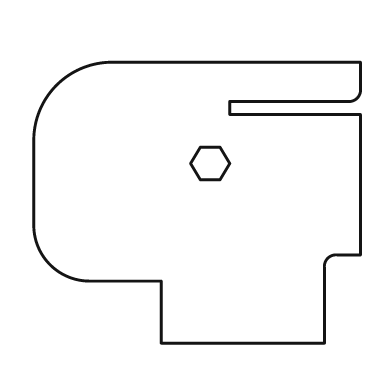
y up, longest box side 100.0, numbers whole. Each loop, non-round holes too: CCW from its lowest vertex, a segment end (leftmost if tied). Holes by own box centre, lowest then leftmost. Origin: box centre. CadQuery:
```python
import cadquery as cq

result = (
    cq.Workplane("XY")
    .moveTo(-11.0, -43.0)
    .lineTo(39.0, -43.0)
    .lineTo(39.0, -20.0)
    .threePointArc((40.0, -17.0), (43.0, -16.0))
    .lineTo(50.0, -16.0)
    .lineTo(50.0, 27.0)
    .lineTo(10.0, 27.0)
    .lineTo(10.0, 31.0)
    .lineTo(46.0, 31.0)
    .threePointArc((49.0, 32.0), (50.0, 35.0))
    .lineTo(50.0, 43.0)
    .lineTo(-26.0, 43.0)
    .threePointArc((-43.0, 36.0), (-50.0, 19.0))
    .lineTo(-50.0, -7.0)
    .threePointArc((-45.0, -19.0), (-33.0, -24.0))
    .lineTo(-11.0, -24.0)
    .close()
    .moveTo(1.0, 7.0)
    .lineTo(7.0, 7.0)
    .lineTo(10.0, 12.0)
    .lineTo(7.0, 17.0)
    .lineTo(1.0, 17.0)
    .lineTo(-2.0, 12.0)
    .close()
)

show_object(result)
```